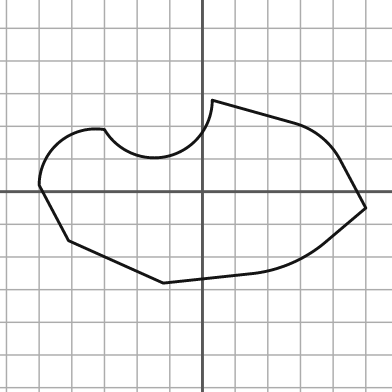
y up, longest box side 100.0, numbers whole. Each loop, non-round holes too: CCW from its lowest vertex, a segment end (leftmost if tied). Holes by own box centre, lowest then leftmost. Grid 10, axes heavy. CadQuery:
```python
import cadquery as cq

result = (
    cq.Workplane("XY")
    .moveTo(-12.0, -28.0)
    .lineTo(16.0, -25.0)
    .threePointArc((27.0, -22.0), (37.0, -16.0))
    .lineTo(50.0, -5.0)
    .lineTo(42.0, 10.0)
    .threePointArc((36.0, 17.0), (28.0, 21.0))
    .lineTo(3.0, 28.0)
    .threePointArc((-10.0, 11.0), (-30.0, 19.0))
    .threePointArc((-44.0, 15.0), (-50.0, 2.0))
    .lineTo(-41.0, -15.0)
    .close()
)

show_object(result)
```